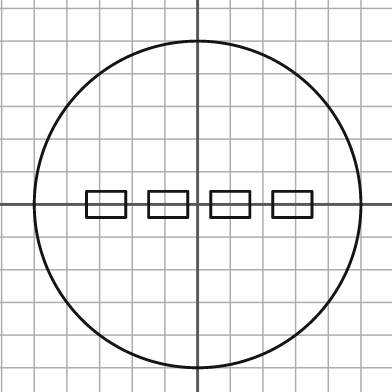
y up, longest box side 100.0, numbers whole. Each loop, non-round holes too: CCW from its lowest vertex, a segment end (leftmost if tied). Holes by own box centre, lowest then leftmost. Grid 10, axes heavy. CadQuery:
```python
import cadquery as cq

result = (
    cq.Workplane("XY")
    .moveTo(0.0, 0.0)
    .circle(50.0)
    .moveTo(-34.0, -4.0)
    .lineTo(-22.0, -4.0)
    .lineTo(-22.0, 4.0)
    .lineTo(-34.0, 4.0)
    .close()
    .moveTo(-15.0, -4.0)
    .lineTo(-3.0, -4.0)
    .lineTo(-3.0, 4.0)
    .lineTo(-15.0, 4.0)
    .close()
    .moveTo(4.0, -4.0)
    .lineTo(16.0, -4.0)
    .lineTo(16.0, 4.0)
    .lineTo(4.0, 4.0)
    .close()
    .moveTo(23.0, -4.0)
    .lineTo(35.0, -4.0)
    .lineTo(35.0, 4.0)
    .lineTo(23.0, 4.0)
    .close()
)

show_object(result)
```